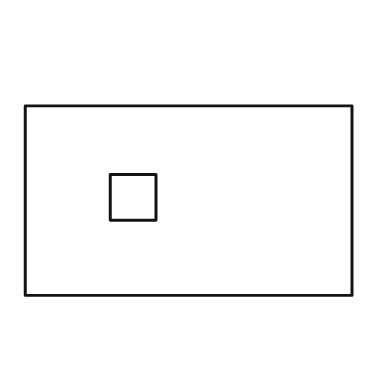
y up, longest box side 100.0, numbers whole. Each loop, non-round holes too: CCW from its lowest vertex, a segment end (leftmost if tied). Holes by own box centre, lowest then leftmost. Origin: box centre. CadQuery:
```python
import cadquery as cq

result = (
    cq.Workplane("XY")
    .moveTo(-50.0, -29.0)
    .lineTo(50.0, -29.0)
    .lineTo(50.0, 29.0)
    .lineTo(-50.0, 29.0)
    .close()
    .moveTo(-24.0, -6.0)
    .lineTo(-10.0, -6.0)
    .lineTo(-10.0, 8.0)
    .lineTo(-24.0, 8.0)
    .close()
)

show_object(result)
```